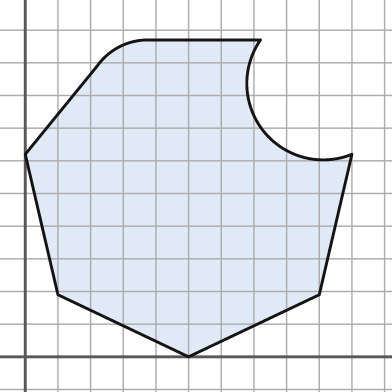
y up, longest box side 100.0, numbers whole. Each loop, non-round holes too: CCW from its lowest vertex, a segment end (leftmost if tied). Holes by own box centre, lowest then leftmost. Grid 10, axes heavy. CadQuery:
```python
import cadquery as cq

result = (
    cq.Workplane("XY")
    .moveTo(50.0, 0.0)
    .lineTo(90.0, 19.0)
    .lineTo(100.0, 62.0)
    .threePointArc((73.0, 69.0), (72.0, 97.0))
    .lineTo(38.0, 97.0)
    .threePointArc((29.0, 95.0), (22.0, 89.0))
    .lineTo(0.0, 62.0)
    .lineTo(10.0, 19.0)
    .close()
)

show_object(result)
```